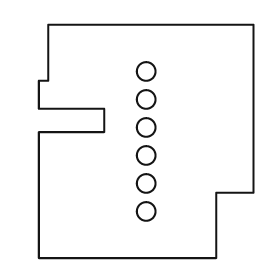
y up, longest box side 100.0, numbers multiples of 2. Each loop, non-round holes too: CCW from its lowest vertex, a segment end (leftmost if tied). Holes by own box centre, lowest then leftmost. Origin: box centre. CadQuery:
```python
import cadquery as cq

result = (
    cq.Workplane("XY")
    .moveTo(-46.0, -50.0)
    .lineTo(30.0, -50.0)
    .lineTo(30.0, -22.0)
    .lineTo(46.0, -22.0)
    .lineTo(46.0, 50.0)
    .lineTo(-42.0, 50.0)
    .lineTo(-42.0, 26.0)
    .lineTo(-46.0, 26.0)
    .lineTo(-46.0, 14.0)
    .lineTo(-18.0, 14.0)
    .lineTo(-18.0, 4.0)
    .lineTo(-46.0, 4.0)
    .close()
    .moveTo(0.0, -30.0)
    .circle(4.0)
    .moveTo(0.0, -18.0)
    .circle(4.0)
    .moveTo(0.0, -6.0)
    .circle(4.0)
    .moveTo(0.0, 6.0)
    .circle(4.0)
    .moveTo(0.0, 18.0)
    .circle(4.0)
    .moveTo(0.0, 30.0)
    .circle(4.0)
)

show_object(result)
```